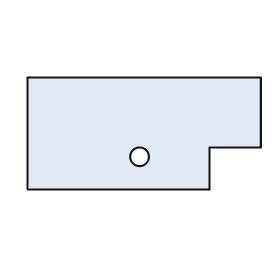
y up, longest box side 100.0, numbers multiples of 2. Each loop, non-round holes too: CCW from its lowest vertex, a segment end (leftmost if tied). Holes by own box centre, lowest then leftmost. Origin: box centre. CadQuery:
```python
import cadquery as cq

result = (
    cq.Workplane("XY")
    .moveTo(-50.0, -24.0)
    .lineTo(28.0, -24.0)
    .lineTo(28.0, -6.0)
    .lineTo(50.0, -6.0)
    .lineTo(50.0, 24.0)
    .lineTo(-50.0, 24.0)
    .close()
    .moveTo(-2.0, -10.0)
    .circle(4.0)
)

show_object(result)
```